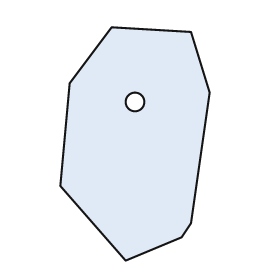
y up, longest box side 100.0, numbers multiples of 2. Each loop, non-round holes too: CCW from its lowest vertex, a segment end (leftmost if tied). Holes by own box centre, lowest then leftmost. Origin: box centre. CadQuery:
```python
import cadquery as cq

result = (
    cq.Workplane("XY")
    .moveTo(-4.0, -50.0)
    .lineTo(20.0, -40.0)
    .lineTo(24.0, -34.0)
    .lineTo(32.0, 22.0)
    .lineTo(24.0, 48.0)
    .lineTo(-10.0, 50.0)
    .lineTo(-28.0, 26.0)
    .lineTo(-32.0, -18.0)
    .close()
    .moveTo(0.0, 18.0)
    .circle(4.0)
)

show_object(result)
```